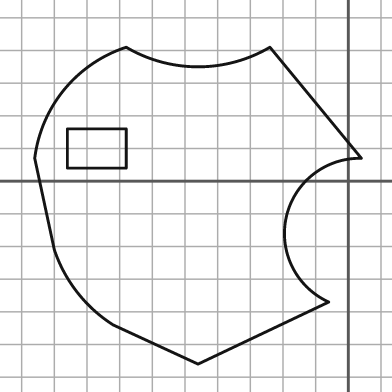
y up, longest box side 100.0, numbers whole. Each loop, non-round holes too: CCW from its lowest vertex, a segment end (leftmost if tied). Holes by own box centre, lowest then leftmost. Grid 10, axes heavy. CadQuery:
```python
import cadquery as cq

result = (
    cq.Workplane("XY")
    .moveTo(-46.0, -56.0)
    .lineTo(-6.0, -37.0)
    .threePointArc((-19.0, -11.0), (4.0, 7.0))
    .lineTo(-24.0, 41.0)
    .threePointArc((-46.0, 35.0), (-68.0, 41.0))
    .threePointArc((-87.0, 28.0), (-96.0, 7.0))
    .lineTo(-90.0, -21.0)
    .threePointArc((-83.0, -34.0), (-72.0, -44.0))
    .close()
    .moveTo(-86.0, 4.0)
    .lineTo(-68.0, 4.0)
    .lineTo(-68.0, 16.0)
    .lineTo(-86.0, 16.0)
    .close()
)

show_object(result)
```